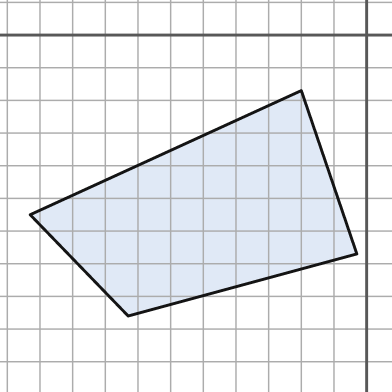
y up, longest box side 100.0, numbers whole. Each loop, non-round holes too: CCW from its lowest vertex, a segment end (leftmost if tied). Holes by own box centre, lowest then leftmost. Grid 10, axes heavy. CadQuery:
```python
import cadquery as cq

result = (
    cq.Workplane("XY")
    .moveTo(-73.0, -86.0)
    .lineTo(-3.0, -67.0)
    .lineTo(-20.0, -17.0)
    .lineTo(-103.0, -55.0)
    .close()
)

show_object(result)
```